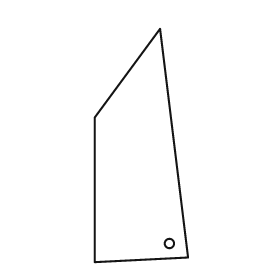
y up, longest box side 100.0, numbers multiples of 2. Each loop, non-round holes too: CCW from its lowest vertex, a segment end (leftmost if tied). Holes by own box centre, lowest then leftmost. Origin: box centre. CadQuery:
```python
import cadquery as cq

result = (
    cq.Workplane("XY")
    .moveTo(-20.0, -50.0)
    .lineTo(20.0, -48.0)
    .lineTo(8.0, 50.0)
    .lineTo(-20.0, 12.0)
    .close()
    .moveTo(12.0, -42.0)
    .circle(2.0)
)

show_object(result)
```